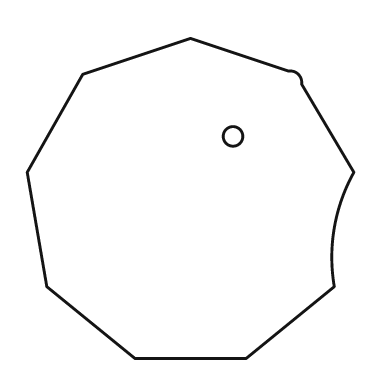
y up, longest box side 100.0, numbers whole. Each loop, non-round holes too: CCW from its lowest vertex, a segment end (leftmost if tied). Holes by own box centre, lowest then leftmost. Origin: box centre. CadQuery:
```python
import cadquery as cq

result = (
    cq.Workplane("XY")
    .moveTo(-17.0, -49.0)
    .lineTo(17.0, -49.0)
    .lineTo(44.0, -27.0)
    .threePointArc((44.0, -9.0), (50.0, 8.0))
    .lineTo(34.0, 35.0)
    .threePointArc((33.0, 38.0), (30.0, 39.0))
    .lineTo(0.0, 49.0)
    .lineTo(-33.0, 38.0)
    .lineTo(-50.0, 8.0)
    .lineTo(-44.0, -27.0)
    .close()
    .moveTo(13.0, 19.0)
    .circle(3.0)
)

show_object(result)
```